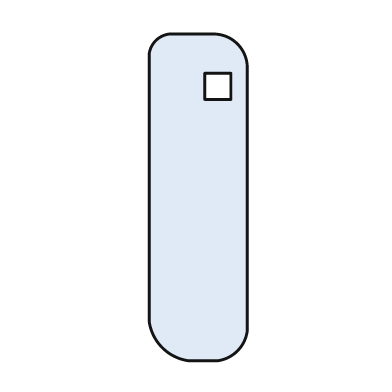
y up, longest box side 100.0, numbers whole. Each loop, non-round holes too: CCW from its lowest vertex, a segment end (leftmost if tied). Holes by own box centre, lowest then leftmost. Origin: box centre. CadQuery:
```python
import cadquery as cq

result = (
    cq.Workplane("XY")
    .moveTo(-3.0, -50.0)
    .lineTo(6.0, -50.0)
    .threePointArc((12.0, -47.0), (15.0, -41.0))
    .lineTo(15.0, 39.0)
    .threePointArc((12.0, 47.0), (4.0, 50.0))
    .lineTo(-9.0, 50.0)
    .threePointArc((-13.0, 48.0), (-15.0, 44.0))
    .lineTo(-15.0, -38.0)
    .threePointArc((-11.0, -46.0), (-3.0, -50.0))
    .close()
    .moveTo(2.0, 30.0)
    .lineTo(10.0, 30.0)
    .lineTo(10.0, 38.0)
    .lineTo(2.0, 38.0)
    .close()
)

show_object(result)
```